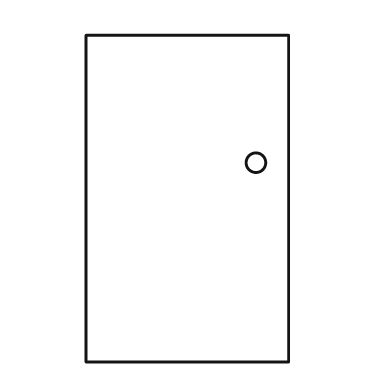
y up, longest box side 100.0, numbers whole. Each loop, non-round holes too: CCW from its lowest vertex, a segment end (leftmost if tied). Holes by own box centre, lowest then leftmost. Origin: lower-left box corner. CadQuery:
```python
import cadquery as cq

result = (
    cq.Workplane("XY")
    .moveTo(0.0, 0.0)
    .lineTo(62.0, 0.0)
    .lineTo(62.0, 100.0)
    .lineTo(0.0, 100.0)
    .close()
    .moveTo(52.0, 61.0)
    .circle(3.0)
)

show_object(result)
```